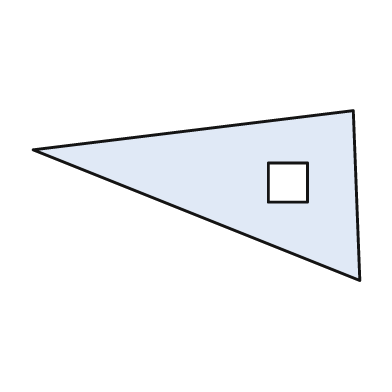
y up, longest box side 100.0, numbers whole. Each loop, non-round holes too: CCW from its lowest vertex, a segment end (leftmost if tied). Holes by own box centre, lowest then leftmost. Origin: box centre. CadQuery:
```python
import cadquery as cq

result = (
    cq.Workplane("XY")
    .moveTo(50.0, -26.0)
    .lineTo(48.0, 26.0)
    .lineTo(-50.0, 14.0)
    .close()
    .moveTo(22.0, -2.0)
    .lineTo(34.0, -2.0)
    .lineTo(34.0, 10.0)
    .lineTo(22.0, 10.0)
    .close()
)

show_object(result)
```